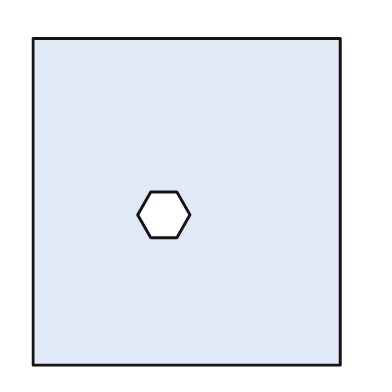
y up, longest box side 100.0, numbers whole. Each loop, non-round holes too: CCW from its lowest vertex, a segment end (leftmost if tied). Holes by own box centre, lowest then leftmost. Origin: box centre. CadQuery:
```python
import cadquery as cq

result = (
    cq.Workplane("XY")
    .moveTo(-47.0, -50.0)
    .lineTo(47.0, -50.0)
    .lineTo(47.0, 50.0)
    .lineTo(-47.0, 50.0)
    .close()
    .moveTo(-11.0, -11.0)
    .lineTo(-3.0, -11.0)
    .lineTo(1.0, -4.0)
    .lineTo(-3.0, 3.0)
    .lineTo(-11.0, 3.0)
    .lineTo(-15.0, -4.0)
    .close()
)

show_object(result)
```